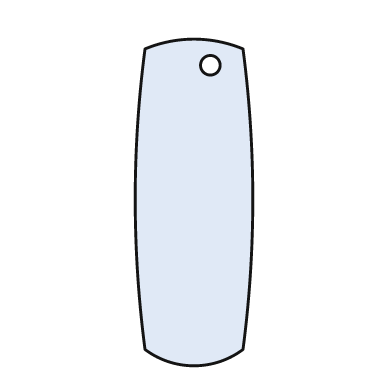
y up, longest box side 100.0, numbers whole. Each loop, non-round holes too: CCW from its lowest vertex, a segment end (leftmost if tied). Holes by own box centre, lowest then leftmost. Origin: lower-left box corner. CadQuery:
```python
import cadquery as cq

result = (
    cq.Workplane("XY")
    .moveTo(3.0, 5.0)
    .threePointArc((18.0, 0.0), (33.0, 5.0))
    .threePointArc((36.0, 51.0), (33.0, 97.0))
    .threePointArc((18.0, 100.0), (3.0, 97.0))
    .threePointArc((0.0, 51.0), (3.0, 5.0))
    .close()
    .moveTo(23.0, 92.0)
    .circle(3.0)
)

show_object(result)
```